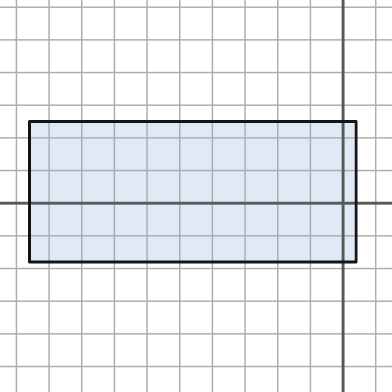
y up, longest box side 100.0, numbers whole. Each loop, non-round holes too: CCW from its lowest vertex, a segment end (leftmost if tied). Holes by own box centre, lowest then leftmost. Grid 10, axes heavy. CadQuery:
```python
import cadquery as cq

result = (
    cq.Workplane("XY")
    .moveTo(-96.0, -18.0)
    .lineTo(4.0, -18.0)
    .lineTo(4.0, 25.0)
    .lineTo(-96.0, 25.0)
    .close()
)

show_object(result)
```